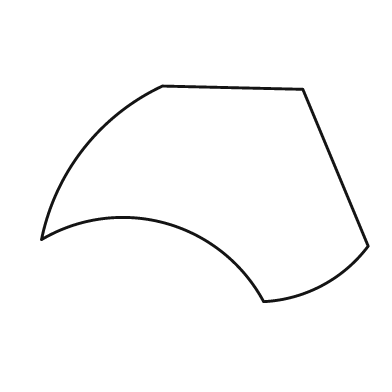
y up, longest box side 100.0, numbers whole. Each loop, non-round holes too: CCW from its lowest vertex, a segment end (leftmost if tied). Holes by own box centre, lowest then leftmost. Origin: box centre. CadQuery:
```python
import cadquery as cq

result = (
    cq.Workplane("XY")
    .moveTo(18.0, -33.0)
    .threePointArc((36.0, -28.0), (50.0, -16.0))
    .lineTo(30.0, 32.0)
    .lineTo(-13.0, 33.0)
    .threePointArc((-37.0, 14.0), (-50.0, -14.0))
    .threePointArc((-12.0, -9.0), (18.0, -33.0))
    .close()
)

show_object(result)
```